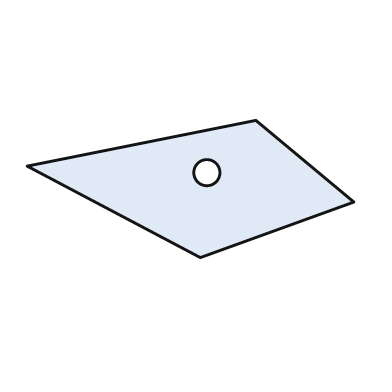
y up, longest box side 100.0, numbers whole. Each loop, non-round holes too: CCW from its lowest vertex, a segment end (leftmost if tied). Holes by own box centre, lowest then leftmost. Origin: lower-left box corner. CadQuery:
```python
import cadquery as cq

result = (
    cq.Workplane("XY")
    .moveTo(53.0, 0.0)
    .lineTo(100.0, 17.0)
    .lineTo(70.0, 42.0)
    .lineTo(0.0, 28.0)
    .close()
    .moveTo(55.0, 26.0)
    .circle(4.0)
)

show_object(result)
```